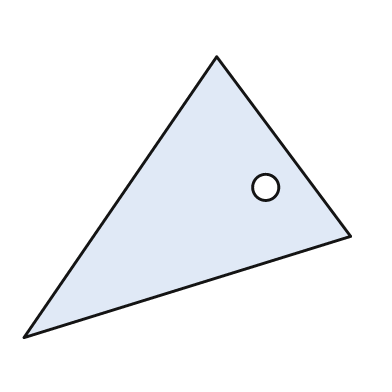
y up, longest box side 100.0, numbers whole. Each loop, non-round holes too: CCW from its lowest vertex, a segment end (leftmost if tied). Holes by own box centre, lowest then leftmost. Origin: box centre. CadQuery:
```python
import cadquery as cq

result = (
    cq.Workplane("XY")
    .moveTo(-50.0, -43.0)
    .lineTo(50.0, -12.0)
    .lineTo(9.0, 43.0)
    .close()
    .moveTo(24.0, 3.0)
    .circle(4.0)
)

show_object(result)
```